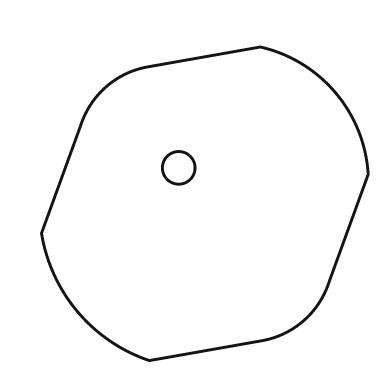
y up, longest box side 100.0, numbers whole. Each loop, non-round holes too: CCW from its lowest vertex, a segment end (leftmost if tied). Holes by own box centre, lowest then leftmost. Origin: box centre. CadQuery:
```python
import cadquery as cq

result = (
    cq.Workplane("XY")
    .moveTo(-17.0, -48.0)
    .lineTo(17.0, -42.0)
    .threePointArc((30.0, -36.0), (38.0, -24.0))
    .lineTo(50.0, 9.0)
    .threePointArc((40.0, 34.0), (17.0, 48.0))
    .lineTo(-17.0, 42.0)
    .threePointArc((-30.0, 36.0), (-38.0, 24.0))
    .lineTo(-50.0, -9.0)
    .threePointArc((-39.0, -33.0), (-17.0, -48.0))
    .close()
    .moveTo(-8.0, 11.0)
    .circle(5.0)
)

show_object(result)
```